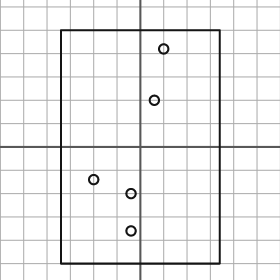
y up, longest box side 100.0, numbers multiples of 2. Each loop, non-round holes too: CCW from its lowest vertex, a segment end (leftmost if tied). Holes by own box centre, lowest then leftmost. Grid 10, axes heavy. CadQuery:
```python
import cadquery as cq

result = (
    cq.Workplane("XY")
    .moveTo(-34.0, -50.0)
    .lineTo(34.0, -50.0)
    .lineTo(34.0, 50.0)
    .lineTo(-34.0, 50.0)
    .close()
    .moveTo(-4.0, -36.0)
    .circle(2.0)
    .moveTo(-4.0, -20.0)
    .circle(2.0)
    .moveTo(-20.0, -14.0)
    .circle(2.0)
    .moveTo(6.0, 20.0)
    .circle(2.0)
    .moveTo(10.0, 42.0)
    .circle(2.0)
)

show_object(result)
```